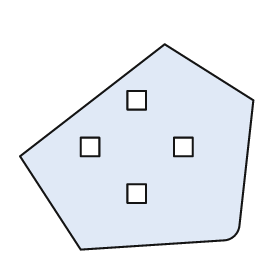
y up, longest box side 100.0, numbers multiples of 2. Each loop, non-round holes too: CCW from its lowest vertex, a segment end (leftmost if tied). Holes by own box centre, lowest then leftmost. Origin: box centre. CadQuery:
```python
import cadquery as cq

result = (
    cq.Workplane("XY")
    .moveTo(-24.0, -44.0)
    .lineTo(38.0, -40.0)
    .threePointArc((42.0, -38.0), (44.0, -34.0))
    .lineTo(50.0, 20.0)
    .lineTo(12.0, 44.0)
    .lineTo(-50.0, -4.0)
    .close()
    .moveTo(-4.0, -24.0)
    .lineTo(4.0, -24.0)
    .lineTo(4.0, -16.0)
    .lineTo(-4.0, -16.0)
    .close()
    .moveTo(-24.0, -4.0)
    .lineTo(-16.0, -4.0)
    .lineTo(-16.0, 4.0)
    .lineTo(-24.0, 4.0)
    .close()
    .moveTo(16.0, -4.0)
    .lineTo(24.0, -4.0)
    .lineTo(24.0, 4.0)
    .lineTo(16.0, 4.0)
    .close()
    .moveTo(-4.0, 16.0)
    .lineTo(4.0, 16.0)
    .lineTo(4.0, 24.0)
    .lineTo(-4.0, 24.0)
    .close()
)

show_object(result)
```